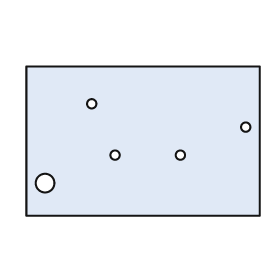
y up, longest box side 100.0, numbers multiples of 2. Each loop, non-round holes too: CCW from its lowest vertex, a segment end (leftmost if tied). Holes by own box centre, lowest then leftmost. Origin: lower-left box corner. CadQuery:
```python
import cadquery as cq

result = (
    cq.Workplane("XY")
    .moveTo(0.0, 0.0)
    .lineTo(100.0, 0.0)
    .lineTo(100.0, 64.0)
    .lineTo(0.0, 64.0)
    .close()
    .moveTo(8.0, 14.0)
    .circle(4.0)
    .moveTo(38.0, 26.0)
    .circle(2.0)
    .moveTo(66.0, 26.0)
    .circle(2.0)
    .moveTo(94.0, 38.0)
    .circle(2.0)
    .moveTo(28.0, 48.0)
    .circle(2.0)
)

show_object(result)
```